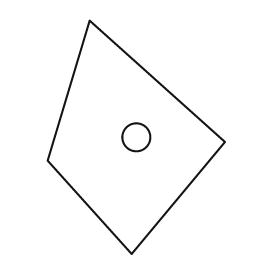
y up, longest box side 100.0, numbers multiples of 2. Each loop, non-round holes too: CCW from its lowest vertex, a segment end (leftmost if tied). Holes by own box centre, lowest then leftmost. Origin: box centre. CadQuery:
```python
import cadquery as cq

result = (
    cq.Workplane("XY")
    .moveTo(-2.0, -50.0)
    .lineTo(38.0, -2.0)
    .lineTo(-20.0, 50.0)
    .lineTo(-38.0, -10.0)
    .close()
    .moveTo(0.0, 0.0)
    .circle(6.0)
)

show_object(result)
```